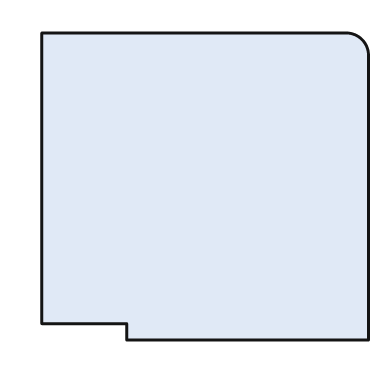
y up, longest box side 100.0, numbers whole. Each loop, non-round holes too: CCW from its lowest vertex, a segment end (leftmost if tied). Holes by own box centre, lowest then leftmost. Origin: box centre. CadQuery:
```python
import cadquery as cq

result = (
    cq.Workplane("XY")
    .moveTo(-24.0, -47.0)
    .lineTo(50.0, -47.0)
    .lineTo(50.0, 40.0)
    .threePointArc((48.0, 45.0), (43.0, 47.0))
    .lineTo(-50.0, 47.0)
    .lineTo(-50.0, -42.0)
    .lineTo(-24.0, -42.0)
    .close()
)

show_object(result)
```